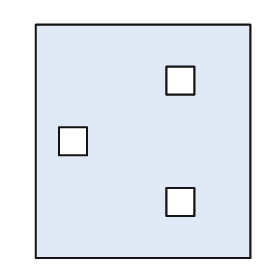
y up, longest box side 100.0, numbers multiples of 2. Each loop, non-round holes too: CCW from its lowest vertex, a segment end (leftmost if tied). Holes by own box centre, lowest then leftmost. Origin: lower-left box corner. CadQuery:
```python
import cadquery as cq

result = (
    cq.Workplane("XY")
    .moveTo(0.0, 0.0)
    .lineTo(92.0, 0.0)
    .lineTo(92.0, 100.0)
    .lineTo(0.0, 100.0)
    .close()
    .moveTo(56.0, 18.0)
    .lineTo(68.0, 18.0)
    .lineTo(68.0, 30.0)
    .lineTo(56.0, 30.0)
    .close()
    .moveTo(10.0, 44.0)
    .lineTo(22.0, 44.0)
    .lineTo(22.0, 56.0)
    .lineTo(10.0, 56.0)
    .close()
    .moveTo(56.0, 70.0)
    .lineTo(68.0, 70.0)
    .lineTo(68.0, 82.0)
    .lineTo(56.0, 82.0)
    .close()
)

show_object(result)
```